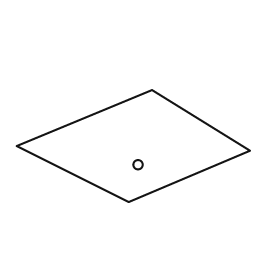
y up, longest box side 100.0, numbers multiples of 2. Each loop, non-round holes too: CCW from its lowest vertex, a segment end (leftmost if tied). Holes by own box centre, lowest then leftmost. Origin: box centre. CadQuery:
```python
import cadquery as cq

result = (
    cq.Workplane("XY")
    .moveTo(-2.0, -24.0)
    .lineTo(50.0, -2.0)
    .lineTo(8.0, 24.0)
    .lineTo(-50.0, 0.0)
    .close()
    .moveTo(2.0, -8.0)
    .circle(2.0)
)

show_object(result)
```